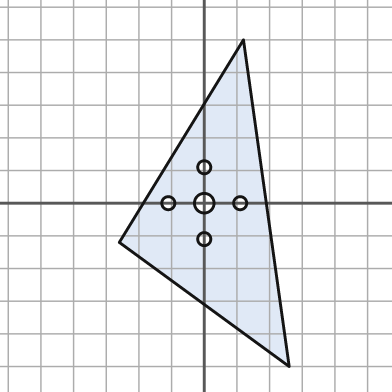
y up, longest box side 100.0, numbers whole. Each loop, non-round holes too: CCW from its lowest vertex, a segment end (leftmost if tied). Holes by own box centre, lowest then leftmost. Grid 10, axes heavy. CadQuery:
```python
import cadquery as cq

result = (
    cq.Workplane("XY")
    .moveTo(26.0, -50.0)
    .lineTo(12.0, 50.0)
    .lineTo(-26.0, -12.0)
    .close()
    .moveTo(0.0, -11.0)
    .circle(2.0)
    .moveTo(-11.0, 0.0)
    .circle(2.0)
    .moveTo(0.0, 0.0)
    .circle(3.0)
    .moveTo(11.0, 0.0)
    .circle(2.0)
    .moveTo(0.0, 11.0)
    .circle(2.0)
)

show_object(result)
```